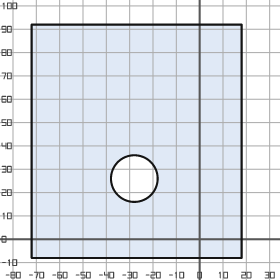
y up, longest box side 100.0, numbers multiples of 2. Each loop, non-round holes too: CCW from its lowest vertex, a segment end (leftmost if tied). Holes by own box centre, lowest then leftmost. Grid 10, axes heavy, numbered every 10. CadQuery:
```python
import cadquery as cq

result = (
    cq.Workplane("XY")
    .moveTo(-72.0, -8.0)
    .lineTo(18.0, -8.0)
    .lineTo(18.0, 92.0)
    .lineTo(-72.0, 92.0)
    .close()
    .moveTo(-28.0, 26.0)
    .circle(10.0)
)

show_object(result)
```